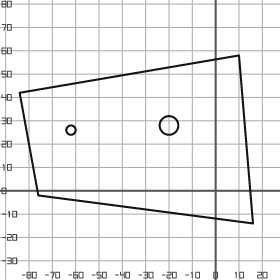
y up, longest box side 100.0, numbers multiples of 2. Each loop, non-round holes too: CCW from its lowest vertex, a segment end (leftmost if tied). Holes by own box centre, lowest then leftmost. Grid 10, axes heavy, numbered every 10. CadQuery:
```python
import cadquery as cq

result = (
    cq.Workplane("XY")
    .moveTo(16.0, -14.0)
    .lineTo(10.0, 58.0)
    .lineTo(-84.0, 42.0)
    .lineTo(-76.0, -2.0)
    .close()
    .moveTo(-62.0, 26.0)
    .circle(2.0)
    .moveTo(-20.0, 28.0)
    .circle(4.0)
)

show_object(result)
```